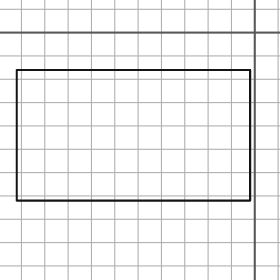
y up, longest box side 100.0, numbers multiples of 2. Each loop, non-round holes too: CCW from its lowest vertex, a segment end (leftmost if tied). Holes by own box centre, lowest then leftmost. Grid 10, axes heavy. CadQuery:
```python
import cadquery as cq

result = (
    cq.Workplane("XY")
    .moveTo(-102.0, -72.0)
    .lineTo(-2.0, -72.0)
    .lineTo(-2.0, -16.0)
    .lineTo(-102.0, -16.0)
    .close()
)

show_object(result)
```